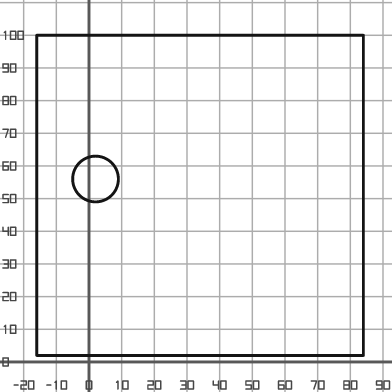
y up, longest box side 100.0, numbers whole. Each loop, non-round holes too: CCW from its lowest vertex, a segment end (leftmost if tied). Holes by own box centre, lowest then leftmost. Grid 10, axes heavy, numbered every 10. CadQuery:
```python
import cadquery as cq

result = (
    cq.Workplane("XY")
    .moveTo(-16.0, 2.0)
    .lineTo(84.0, 2.0)
    .lineTo(84.0, 100.0)
    .lineTo(-16.0, 100.0)
    .close()
    .moveTo(2.0, 56.0)
    .circle(7.0)
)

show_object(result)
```